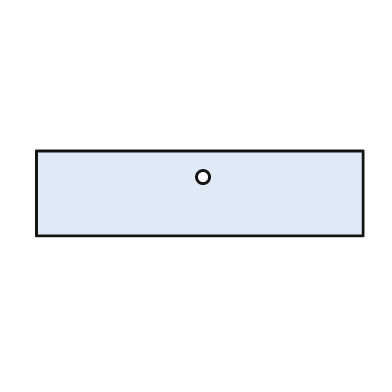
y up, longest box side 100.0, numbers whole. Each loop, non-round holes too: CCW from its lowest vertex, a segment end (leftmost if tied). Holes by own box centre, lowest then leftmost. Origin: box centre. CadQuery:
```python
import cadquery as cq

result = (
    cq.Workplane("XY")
    .moveTo(-50.0, -13.0)
    .lineTo(50.0, -13.0)
    .lineTo(50.0, 13.0)
    .lineTo(-50.0, 13.0)
    .close()
    .moveTo(1.0, 5.0)
    .circle(2.0)
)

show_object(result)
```